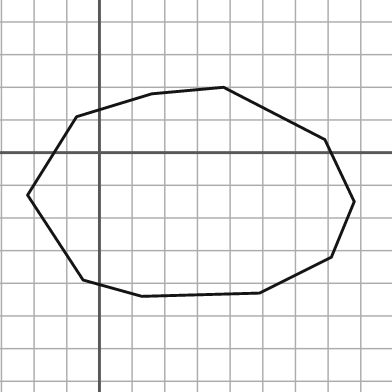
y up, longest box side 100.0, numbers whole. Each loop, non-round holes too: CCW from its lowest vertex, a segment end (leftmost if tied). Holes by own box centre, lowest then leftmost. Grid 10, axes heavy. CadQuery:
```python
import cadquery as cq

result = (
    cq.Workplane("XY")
    .moveTo(13.0, -44.0)
    .lineTo(49.0, -43.0)
    .lineTo(71.0, -32.0)
    .lineTo(78.0, -15.0)
    .lineTo(69.0, 4.0)
    .lineTo(38.0, 20.0)
    .lineTo(16.0, 18.0)
    .lineTo(-7.0, 11.0)
    .lineTo(-22.0, -13.0)
    .lineTo(-5.0, -39.0)
    .close()
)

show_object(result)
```